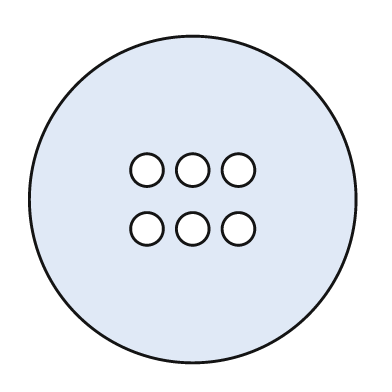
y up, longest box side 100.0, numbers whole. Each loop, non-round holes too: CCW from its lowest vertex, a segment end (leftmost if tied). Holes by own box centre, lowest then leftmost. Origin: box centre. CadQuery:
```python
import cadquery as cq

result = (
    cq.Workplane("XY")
    .moveTo(0.0, 0.0)
    .circle(50.0)
    .moveTo(-14.0, -9.0)
    .circle(5.0)
    .moveTo(0.0, -9.0)
    .circle(5.0)
    .moveTo(14.0, -9.0)
    .circle(5.0)
    .moveTo(-14.0, 9.0)
    .circle(5.0)
    .moveTo(0.0, 9.0)
    .circle(5.0)
    .moveTo(14.0, 9.0)
    .circle(5.0)
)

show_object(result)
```